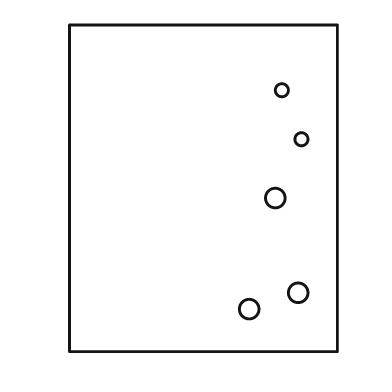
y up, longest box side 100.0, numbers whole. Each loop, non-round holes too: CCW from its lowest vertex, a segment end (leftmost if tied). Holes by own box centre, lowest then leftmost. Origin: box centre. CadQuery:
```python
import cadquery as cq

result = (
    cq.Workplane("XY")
    .moveTo(-41.0, -50.0)
    .lineTo(41.0, -50.0)
    .lineTo(41.0, 50.0)
    .lineTo(-41.0, 50.0)
    .close()
    .moveTo(14.0, -37.0)
    .circle(3.0)
    .moveTo(29.0, -32.0)
    .circle(3.0)
    .moveTo(22.0, -3.0)
    .circle(3.0)
    .moveTo(30.0, 15.0)
    .circle(2.0)
    .moveTo(24.0, 30.0)
    .circle(2.0)
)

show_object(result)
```